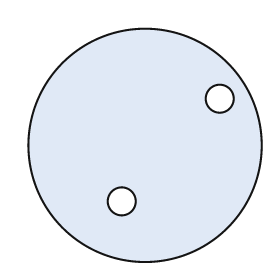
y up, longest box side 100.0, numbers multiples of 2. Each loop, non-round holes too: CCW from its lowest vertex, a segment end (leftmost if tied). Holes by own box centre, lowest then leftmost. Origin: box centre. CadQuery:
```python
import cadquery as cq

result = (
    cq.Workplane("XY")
    .moveTo(0.0, 0.0)
    .circle(50.0)
    .moveTo(-10.0, -24.0)
    .circle(6.0)
    .moveTo(32.0, 20.0)
    .circle(6.0)
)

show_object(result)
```